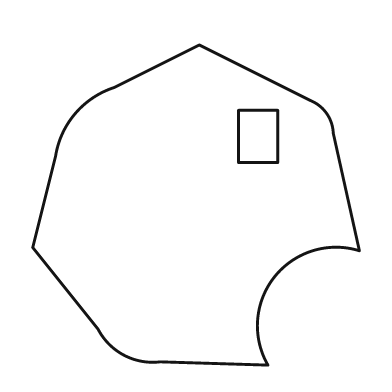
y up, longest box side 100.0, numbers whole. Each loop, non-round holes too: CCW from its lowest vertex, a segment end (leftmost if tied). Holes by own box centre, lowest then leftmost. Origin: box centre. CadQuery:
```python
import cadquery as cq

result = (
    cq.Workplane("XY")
    .moveTo(22.0, -49.0)
    .threePointArc((24.0, -22.0), (50.0, -14.0))
    .lineTo(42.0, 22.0)
    .threePointArc((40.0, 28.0), (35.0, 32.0))
    .lineTo(1.0, 49.0)
    .lineTo(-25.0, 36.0)
    .threePointArc((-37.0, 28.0), (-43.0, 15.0))
    .lineTo(-50.0, -13.0)
    .lineTo(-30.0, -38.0)
    .threePointArc((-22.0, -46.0), (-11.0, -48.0))
    .close()
    .moveTo(13.0, 13.0)
    .lineTo(25.0, 13.0)
    .lineTo(25.0, 29.0)
    .lineTo(13.0, 29.0)
    .close()
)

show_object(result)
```